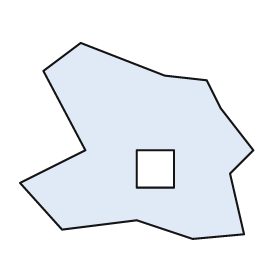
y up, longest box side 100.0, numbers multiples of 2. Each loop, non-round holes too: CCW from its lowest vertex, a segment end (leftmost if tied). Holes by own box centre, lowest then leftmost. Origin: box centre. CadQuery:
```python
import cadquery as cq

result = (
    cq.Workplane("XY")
    .moveTo(24.0, -42.0)
    .lineTo(46.0, -40.0)
    .lineTo(40.0, -14.0)
    .lineTo(50.0, -4.0)
    .lineTo(36.0, 14.0)
    .lineTo(30.0, 26.0)
    .lineTo(12.0, 28.0)
    .lineTo(-24.0, 42.0)
    .lineTo(-40.0, 30.0)
    .lineTo(-22.0, -4.0)
    .lineTo(-50.0, -18.0)
    .lineTo(-32.0, -38.0)
    .lineTo(0.0, -34.0)
    .close()
    .moveTo(0.0, -20.0)
    .lineTo(16.0, -20.0)
    .lineTo(16.0, -4.0)
    .lineTo(0.0, -4.0)
    .close()
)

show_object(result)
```